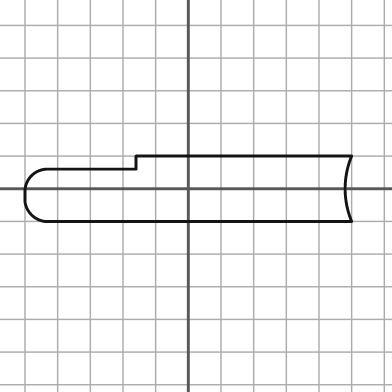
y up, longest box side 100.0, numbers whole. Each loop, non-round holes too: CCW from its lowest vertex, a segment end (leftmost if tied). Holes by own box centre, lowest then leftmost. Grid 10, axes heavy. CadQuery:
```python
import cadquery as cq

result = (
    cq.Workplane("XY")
    .moveTo(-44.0, -10.0)
    .lineTo(50.0, -10.0)
    .threePointArc((48.0, 0.0), (50.0, 10.0))
    .lineTo(-16.0, 10.0)
    .lineTo(-16.0, 6.0)
    .lineTo(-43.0, 6.0)
    .threePointArc((-48.0, 4.0), (-50.0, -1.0))
    .lineTo(-50.0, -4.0)
    .threePointArc((-48.0, -8.0), (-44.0, -10.0))
    .close()
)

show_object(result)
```